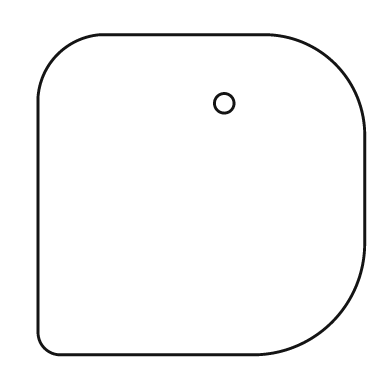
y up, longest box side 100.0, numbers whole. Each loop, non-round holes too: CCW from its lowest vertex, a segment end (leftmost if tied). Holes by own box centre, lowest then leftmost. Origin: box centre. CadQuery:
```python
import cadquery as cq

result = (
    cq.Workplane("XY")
    .moveTo(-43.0, -49.0)
    .lineTo(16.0, -49.0)
    .threePointArc((40.0, -39.0), (50.0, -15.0))
    .lineTo(50.0, 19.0)
    .threePointArc((41.0, 40.0), (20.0, 49.0))
    .lineTo(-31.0, 49.0)
    .threePointArc((-44.0, 43.0), (-50.0, 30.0))
    .lineTo(-50.0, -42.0)
    .threePointArc((-48.0, -47.0), (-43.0, -49.0))
    .close()
    .moveTo(7.0, 28.0)
    .circle(3.0)
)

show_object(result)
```